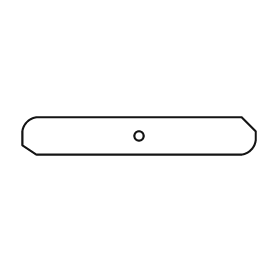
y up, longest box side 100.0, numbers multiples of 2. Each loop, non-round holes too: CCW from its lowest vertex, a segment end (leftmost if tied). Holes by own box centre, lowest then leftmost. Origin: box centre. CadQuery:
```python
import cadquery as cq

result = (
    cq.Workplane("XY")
    .moveTo(-44.0, -8.0)
    .lineTo(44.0, -8.0)
    .threePointArc((48.0, -6.0), (50.0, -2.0))
    .lineTo(50.0, 2.0)
    .lineTo(44.0, 8.0)
    .lineTo(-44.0, 8.0)
    .threePointArc((-48.0, 6.0), (-50.0, 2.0))
    .lineTo(-50.0, -4.0)
    .close()
    .moveTo(0.0, 0.0)
    .circle(2.0)
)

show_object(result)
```